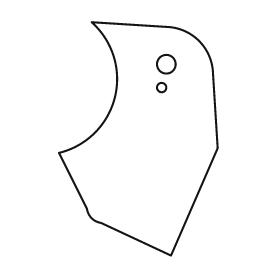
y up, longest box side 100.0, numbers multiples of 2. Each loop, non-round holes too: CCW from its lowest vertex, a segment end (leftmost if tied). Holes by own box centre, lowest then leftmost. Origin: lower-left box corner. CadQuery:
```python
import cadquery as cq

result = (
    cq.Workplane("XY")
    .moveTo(48.0, 0.0)
    .lineTo(68.0, 46.0)
    .lineTo(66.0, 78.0)
    .threePointArc((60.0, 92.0), (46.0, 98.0))
    .lineTo(14.0, 100.0)
    .threePointArc((24.0, 68.0), (0.0, 44.0))
    .lineTo(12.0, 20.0)
    .threePointArc((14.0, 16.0), (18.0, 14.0))
    .close()
    .moveTo(44.0, 72.0)
    .circle(2.0)
    .moveTo(46.0, 82.0)
    .circle(4.0)
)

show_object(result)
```